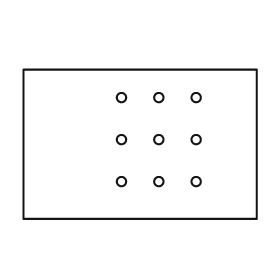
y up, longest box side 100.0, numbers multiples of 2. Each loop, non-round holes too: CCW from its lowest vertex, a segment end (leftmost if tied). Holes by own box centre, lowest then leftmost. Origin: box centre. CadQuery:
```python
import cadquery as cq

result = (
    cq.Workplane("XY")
    .moveTo(-50.0, -32.0)
    .lineTo(50.0, -32.0)
    .lineTo(50.0, 32.0)
    .lineTo(-50.0, 32.0)
    .close()
    .moveTo(-8.0, -16.0)
    .circle(2.0)
    .moveTo(8.0, -16.0)
    .circle(2.0)
    .moveTo(24.0, -16.0)
    .circle(2.0)
    .moveTo(-8.0, 2.0)
    .circle(2.0)
    .moveTo(8.0, 2.0)
    .circle(2.0)
    .moveTo(24.0, 2.0)
    .circle(2.0)
    .moveTo(-8.0, 20.0)
    .circle(2.0)
    .moveTo(8.0, 20.0)
    .circle(2.0)
    .moveTo(24.0, 20.0)
    .circle(2.0)
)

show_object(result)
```